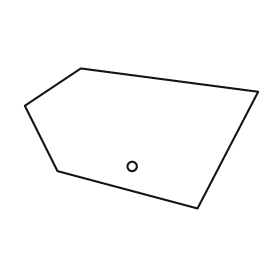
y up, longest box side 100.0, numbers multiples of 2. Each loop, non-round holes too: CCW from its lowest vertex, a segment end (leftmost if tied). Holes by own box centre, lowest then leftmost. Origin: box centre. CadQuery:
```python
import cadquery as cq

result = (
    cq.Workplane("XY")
    .moveTo(24.0, -30.0)
    .lineTo(50.0, 20.0)
    .lineTo(-26.0, 30.0)
    .lineTo(-50.0, 14.0)
    .lineTo(-36.0, -14.0)
    .close()
    .moveTo(-4.0, -12.0)
    .circle(2.0)
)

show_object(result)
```